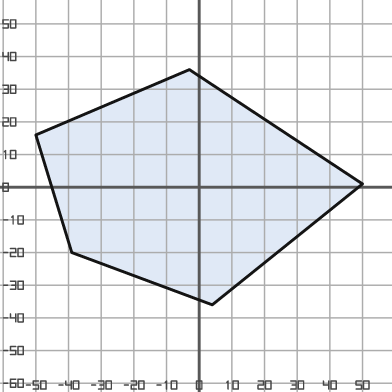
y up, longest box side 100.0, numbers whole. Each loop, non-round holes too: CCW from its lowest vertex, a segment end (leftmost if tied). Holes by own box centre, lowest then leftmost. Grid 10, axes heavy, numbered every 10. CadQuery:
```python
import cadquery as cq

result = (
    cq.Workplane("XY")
    .moveTo(4.0, -36.0)
    .lineTo(50.0, 1.0)
    .lineTo(-3.0, 36.0)
    .lineTo(-50.0, 16.0)
    .lineTo(-39.0, -20.0)
    .close()
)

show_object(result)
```